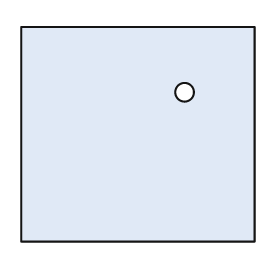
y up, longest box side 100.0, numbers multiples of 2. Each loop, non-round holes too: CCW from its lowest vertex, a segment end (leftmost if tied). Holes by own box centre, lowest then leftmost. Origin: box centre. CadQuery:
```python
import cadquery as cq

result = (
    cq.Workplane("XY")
    .moveTo(-50.0, -46.0)
    .lineTo(50.0, -46.0)
    .lineTo(50.0, 46.0)
    .lineTo(-50.0, 46.0)
    .close()
    .moveTo(20.0, 18.0)
    .circle(4.0)
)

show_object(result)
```